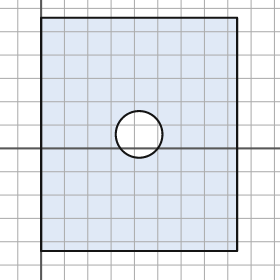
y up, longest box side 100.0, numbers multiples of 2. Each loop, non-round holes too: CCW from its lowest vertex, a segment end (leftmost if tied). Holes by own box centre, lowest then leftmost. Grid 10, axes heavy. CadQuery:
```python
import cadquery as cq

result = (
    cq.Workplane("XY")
    .moveTo(0.0, -44.0)
    .lineTo(84.0, -44.0)
    .lineTo(84.0, 56.0)
    .lineTo(0.0, 56.0)
    .close()
    .moveTo(42.0, 6.0)
    .circle(10.0)
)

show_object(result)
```